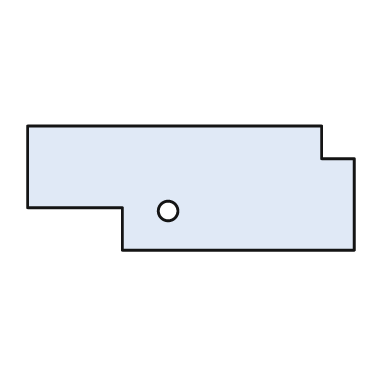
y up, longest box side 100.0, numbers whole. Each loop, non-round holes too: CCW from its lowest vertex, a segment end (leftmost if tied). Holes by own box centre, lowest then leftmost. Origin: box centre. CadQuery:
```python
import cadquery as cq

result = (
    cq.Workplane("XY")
    .moveTo(-21.0, -19.0)
    .lineTo(50.0, -19.0)
    .lineTo(50.0, 9.0)
    .lineTo(40.0, 9.0)
    .lineTo(40.0, 19.0)
    .lineTo(-50.0, 19.0)
    .lineTo(-50.0, -6.0)
    .lineTo(-21.0, -6.0)
    .close()
    .moveTo(-7.0, -7.0)
    .circle(3.0)
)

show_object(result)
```